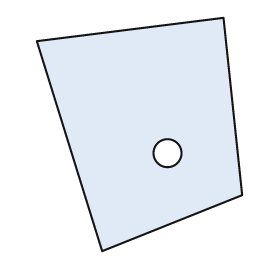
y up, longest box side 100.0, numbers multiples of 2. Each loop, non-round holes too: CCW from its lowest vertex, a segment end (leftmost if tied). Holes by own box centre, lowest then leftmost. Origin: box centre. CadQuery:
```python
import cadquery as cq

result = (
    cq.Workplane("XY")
    .moveTo(-16.0, -50.0)
    .lineTo(44.0, -26.0)
    .lineTo(36.0, 50.0)
    .lineTo(-44.0, 40.0)
    .close()
    .moveTo(12.0, -8.0)
    .circle(6.0)
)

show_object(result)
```